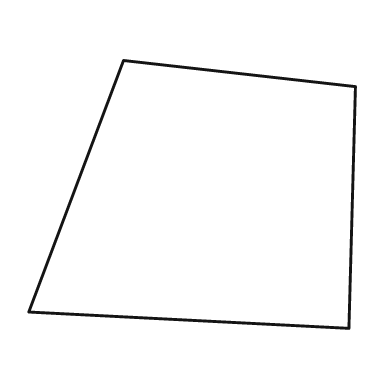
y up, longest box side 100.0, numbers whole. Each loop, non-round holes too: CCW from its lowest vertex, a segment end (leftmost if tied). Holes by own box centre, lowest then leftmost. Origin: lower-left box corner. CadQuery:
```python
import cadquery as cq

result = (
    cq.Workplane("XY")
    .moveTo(98.0, 0.0)
    .lineTo(100.0, 74.0)
    .lineTo(29.0, 82.0)
    .lineTo(0.0, 5.0)
    .close()
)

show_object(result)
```